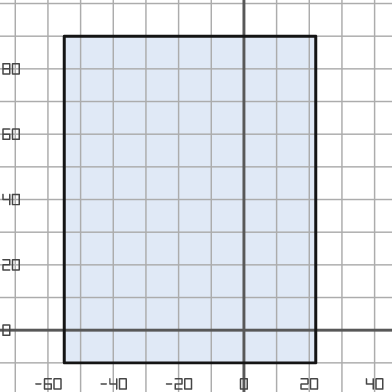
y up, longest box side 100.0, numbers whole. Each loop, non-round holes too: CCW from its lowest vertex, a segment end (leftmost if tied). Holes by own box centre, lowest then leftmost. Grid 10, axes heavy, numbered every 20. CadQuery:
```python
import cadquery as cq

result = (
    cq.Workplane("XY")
    .moveTo(-55.0, -10.0)
    .lineTo(22.0, -10.0)
    .lineTo(22.0, 90.0)
    .lineTo(-55.0, 90.0)
    .close()
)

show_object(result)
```